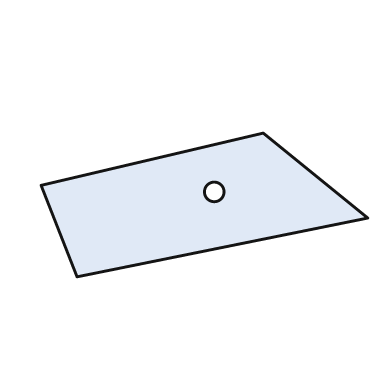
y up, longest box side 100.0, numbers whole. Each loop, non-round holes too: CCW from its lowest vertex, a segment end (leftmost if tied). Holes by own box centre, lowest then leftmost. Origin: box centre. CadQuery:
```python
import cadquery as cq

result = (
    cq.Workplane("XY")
    .moveTo(-39.0, -22.0)
    .lineTo(50.0, -4.0)
    .lineTo(18.0, 22.0)
    .lineTo(-50.0, 6.0)
    .close()
    .moveTo(3.0, 4.0)
    .circle(3.0)
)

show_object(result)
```